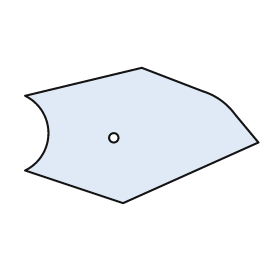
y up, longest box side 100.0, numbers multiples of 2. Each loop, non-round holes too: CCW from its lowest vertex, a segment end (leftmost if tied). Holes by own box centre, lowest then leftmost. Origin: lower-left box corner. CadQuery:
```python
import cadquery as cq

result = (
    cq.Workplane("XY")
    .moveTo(42.0, 0.0)
    .lineTo(100.0, 26.0)
    .lineTo(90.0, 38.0)
    .threePointArc((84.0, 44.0), (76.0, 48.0))
    .lineTo(50.0, 58.0)
    .lineTo(0.0, 46.0)
    .threePointArc((10.0, 30.0), (0.0, 14.0))
    .close()
    .moveTo(38.0, 28.0)
    .circle(2.0)
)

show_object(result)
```